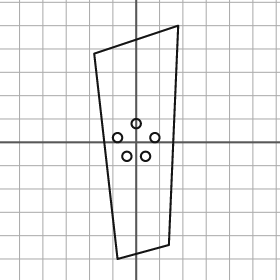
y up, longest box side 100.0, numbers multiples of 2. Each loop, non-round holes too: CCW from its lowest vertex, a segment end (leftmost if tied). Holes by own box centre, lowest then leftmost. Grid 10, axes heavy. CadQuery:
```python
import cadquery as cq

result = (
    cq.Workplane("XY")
    .moveTo(-8.0, -50.0)
    .lineTo(14.0, -44.0)
    .lineTo(18.0, 50.0)
    .lineTo(-18.0, 38.0)
    .close()
    .moveTo(-4.0, -6.0)
    .circle(2.0)
    .moveTo(4.0, -6.0)
    .circle(2.0)
    .moveTo(-8.0, 2.0)
    .circle(2.0)
    .moveTo(8.0, 2.0)
    .circle(2.0)
    .moveTo(0.0, 8.0)
    .circle(2.0)
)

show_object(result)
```